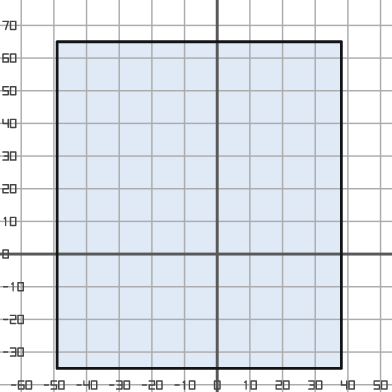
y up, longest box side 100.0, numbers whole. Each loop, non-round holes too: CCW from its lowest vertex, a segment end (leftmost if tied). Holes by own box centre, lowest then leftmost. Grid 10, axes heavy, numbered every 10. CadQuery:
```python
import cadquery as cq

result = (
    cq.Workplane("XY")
    .moveTo(-49.0, -35.0)
    .lineTo(38.0, -35.0)
    .lineTo(38.0, 65.0)
    .lineTo(-49.0, 65.0)
    .close()
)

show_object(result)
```